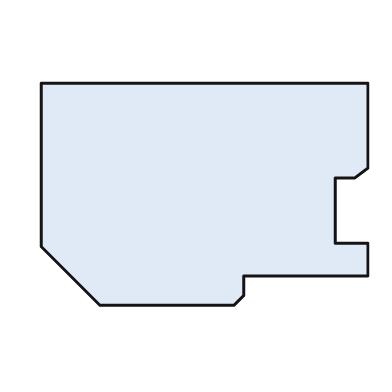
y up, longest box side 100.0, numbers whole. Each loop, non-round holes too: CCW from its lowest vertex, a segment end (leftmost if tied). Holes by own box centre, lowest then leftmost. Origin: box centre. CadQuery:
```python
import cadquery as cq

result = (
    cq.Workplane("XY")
    .moveTo(-32.0, -34.0)
    .lineTo(9.0, -34.0)
    .lineTo(12.0, -31.0)
    .lineTo(12.0, -25.0)
    .lineTo(50.0, -25.0)
    .lineTo(50.0, -15.0)
    .lineTo(40.0, -15.0)
    .lineTo(40.0, 5.0)
    .lineTo(46.0, 5.0)
    .lineTo(50.0, 8.0)
    .lineTo(50.0, 34.0)
    .lineTo(-50.0, 34.0)
    .lineTo(-50.0, -16.0)
    .close()
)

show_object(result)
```